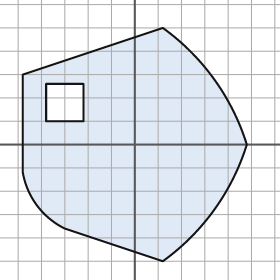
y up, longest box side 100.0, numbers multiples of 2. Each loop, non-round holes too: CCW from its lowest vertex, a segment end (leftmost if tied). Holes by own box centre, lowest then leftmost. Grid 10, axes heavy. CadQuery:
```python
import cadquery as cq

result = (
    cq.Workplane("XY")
    .moveTo(12.0, -50.0)
    .threePointArc((34.0, -28.0), (48.0, 0.0))
    .threePointArc((34.0, 28.0), (12.0, 50.0))
    .lineTo(-48.0, 30.0)
    .lineTo(-48.0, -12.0)
    .threePointArc((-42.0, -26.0), (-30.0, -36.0))
    .close()
    .moveTo(-38.0, 10.0)
    .lineTo(-22.0, 10.0)
    .lineTo(-22.0, 26.0)
    .lineTo(-38.0, 26.0)
    .close()
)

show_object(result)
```